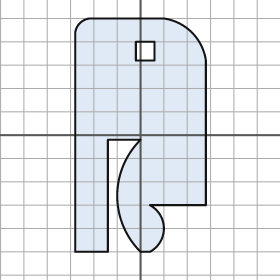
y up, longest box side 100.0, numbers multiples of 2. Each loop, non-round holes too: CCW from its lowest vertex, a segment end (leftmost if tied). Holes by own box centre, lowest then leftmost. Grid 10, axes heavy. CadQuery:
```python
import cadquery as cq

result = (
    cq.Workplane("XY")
    .moveTo(-28.0, -50.0)
    .lineTo(-14.0, -50.0)
    .lineTo(-14.0, -2.0)
    .lineTo(0.0, -2.0)
    .threePointArc((-10.0, -26.0), (0.0, -50.0))
    .lineTo(4.0, -50.0)
    .threePointArc((10.0, -40.0), (4.0, -30.0))
    .lineTo(28.0, -30.0)
    .lineTo(28.0, 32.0)
    .threePointArc((22.0, 44.0), (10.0, 50.0))
    .lineTo(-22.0, 50.0)
    .threePointArc((-26.0, 48.0), (-28.0, 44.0))
    .close()
    .moveTo(-2.0, 32.0)
    .lineTo(6.0, 32.0)
    .lineTo(6.0, 40.0)
    .lineTo(-2.0, 40.0)
    .close()
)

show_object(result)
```